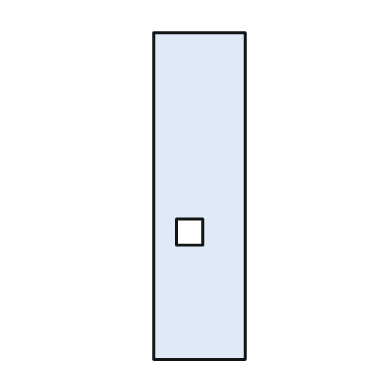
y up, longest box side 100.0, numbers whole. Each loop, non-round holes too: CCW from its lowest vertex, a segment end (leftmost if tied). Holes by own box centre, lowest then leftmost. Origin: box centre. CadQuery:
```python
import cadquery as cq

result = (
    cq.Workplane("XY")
    .moveTo(-14.0, -50.0)
    .lineTo(14.0, -50.0)
    .lineTo(14.0, 50.0)
    .lineTo(-14.0, 50.0)
    .close()
    .moveTo(-7.0, -15.0)
    .lineTo(1.0, -15.0)
    .lineTo(1.0, -7.0)
    .lineTo(-7.0, -7.0)
    .close()
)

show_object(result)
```